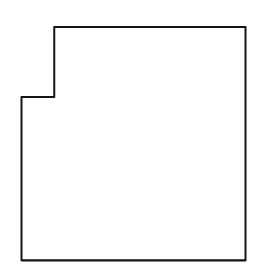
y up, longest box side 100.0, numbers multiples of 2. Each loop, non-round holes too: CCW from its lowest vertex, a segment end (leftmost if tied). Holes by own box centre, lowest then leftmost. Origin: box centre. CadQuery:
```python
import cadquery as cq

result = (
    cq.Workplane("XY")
    .moveTo(-48.0, -50.0)
    .lineTo(48.0, -50.0)
    .lineTo(48.0, 50.0)
    .lineTo(-34.0, 50.0)
    .lineTo(-34.0, 20.0)
    .lineTo(-48.0, 20.0)
    .close()
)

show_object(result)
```